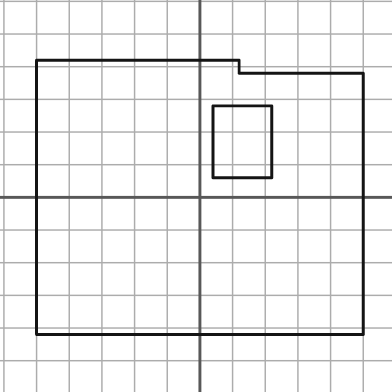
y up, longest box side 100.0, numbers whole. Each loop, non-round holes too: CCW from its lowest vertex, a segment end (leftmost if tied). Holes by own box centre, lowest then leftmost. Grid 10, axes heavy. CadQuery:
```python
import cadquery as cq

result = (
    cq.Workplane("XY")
    .moveTo(-50.0, -42.0)
    .lineTo(50.0, -42.0)
    .lineTo(50.0, 38.0)
    .lineTo(12.0, 38.0)
    .lineTo(12.0, 42.0)
    .lineTo(-50.0, 42.0)
    .close()
    .moveTo(4.0, 6.0)
    .lineTo(22.0, 6.0)
    .lineTo(22.0, 28.0)
    .lineTo(4.0, 28.0)
    .close()
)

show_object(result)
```